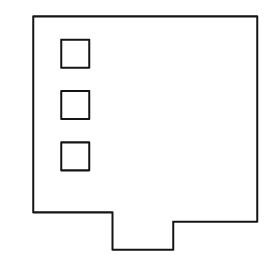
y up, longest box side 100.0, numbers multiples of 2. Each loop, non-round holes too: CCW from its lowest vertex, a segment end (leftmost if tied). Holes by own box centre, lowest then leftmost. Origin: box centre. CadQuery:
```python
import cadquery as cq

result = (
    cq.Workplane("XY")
    .moveTo(-14.0, -50.0)
    .lineTo(12.0, -50.0)
    .lineTo(12.0, -38.0)
    .lineTo(48.0, -38.0)
    .lineTo(48.0, 50.0)
    .lineTo(-48.0, 50.0)
    .lineTo(-48.0, -34.0)
    .lineTo(-14.0, -34.0)
    .close()
    .moveTo(-36.0, -16.0)
    .lineTo(-24.0, -16.0)
    .lineTo(-24.0, -4.0)
    .lineTo(-36.0, -4.0)
    .close()
    .moveTo(-36.0, 6.0)
    .lineTo(-24.0, 6.0)
    .lineTo(-24.0, 18.0)
    .lineTo(-36.0, 18.0)
    .close()
    .moveTo(-36.0, 28.0)
    .lineTo(-24.0, 28.0)
    .lineTo(-24.0, 40.0)
    .lineTo(-36.0, 40.0)
    .close()
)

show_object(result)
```